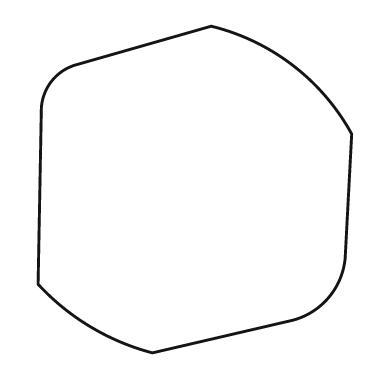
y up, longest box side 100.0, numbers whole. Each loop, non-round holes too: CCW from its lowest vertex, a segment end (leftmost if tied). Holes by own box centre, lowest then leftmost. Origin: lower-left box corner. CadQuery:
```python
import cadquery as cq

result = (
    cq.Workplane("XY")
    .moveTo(35.0, 0.0)
    .lineTo(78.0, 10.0)
    .threePointArc((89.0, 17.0), (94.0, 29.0))
    .lineTo(96.0, 67.0)
    .threePointArc((78.0, 88.0), (53.0, 100.0))
    .lineTo(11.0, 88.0)
    .threePointArc((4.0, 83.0), (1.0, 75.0))
    .lineTo(0.0, 21.0)
    .threePointArc((16.0, 8.0), (35.0, 0.0))
    .close()
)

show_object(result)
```